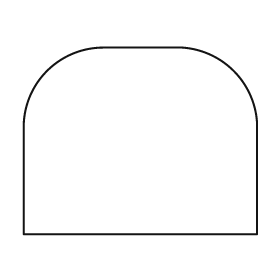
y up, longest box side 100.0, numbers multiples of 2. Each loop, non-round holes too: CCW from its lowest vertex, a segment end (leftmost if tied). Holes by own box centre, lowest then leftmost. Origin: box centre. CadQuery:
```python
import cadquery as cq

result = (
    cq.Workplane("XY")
    .moveTo(-50.0, -40.0)
    .lineTo(50.0, -40.0)
    .lineTo(50.0, 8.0)
    .threePointArc((40.0, 30.0), (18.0, 40.0))
    .lineTo(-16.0, 40.0)
    .threePointArc((-40.0, 30.0), (-50.0, 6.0))
    .close()
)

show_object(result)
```